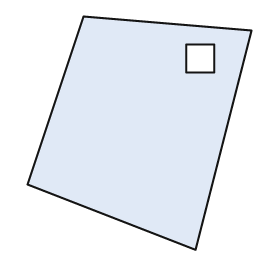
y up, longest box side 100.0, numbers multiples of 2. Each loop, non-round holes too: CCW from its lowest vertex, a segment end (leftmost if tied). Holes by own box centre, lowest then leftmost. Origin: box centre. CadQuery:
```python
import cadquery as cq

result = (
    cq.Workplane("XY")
    .moveTo(24.0, -50.0)
    .lineTo(48.0, 44.0)
    .lineTo(-24.0, 50.0)
    .lineTo(-48.0, -22.0)
    .close()
    .moveTo(20.0, 26.0)
    .lineTo(32.0, 26.0)
    .lineTo(32.0, 38.0)
    .lineTo(20.0, 38.0)
    .close()
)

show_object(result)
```